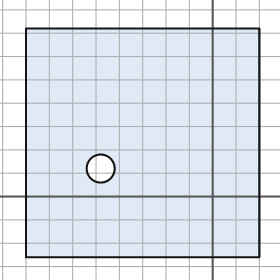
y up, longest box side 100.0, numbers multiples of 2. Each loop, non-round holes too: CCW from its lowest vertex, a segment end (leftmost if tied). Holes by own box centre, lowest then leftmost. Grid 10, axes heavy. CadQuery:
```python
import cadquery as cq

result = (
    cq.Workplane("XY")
    .moveTo(-80.0, -26.0)
    .lineTo(20.0, -26.0)
    .lineTo(20.0, 72.0)
    .lineTo(-80.0, 72.0)
    .close()
    .moveTo(-48.0, 12.0)
    .circle(6.0)
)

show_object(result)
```